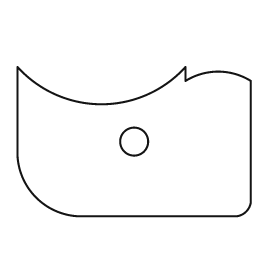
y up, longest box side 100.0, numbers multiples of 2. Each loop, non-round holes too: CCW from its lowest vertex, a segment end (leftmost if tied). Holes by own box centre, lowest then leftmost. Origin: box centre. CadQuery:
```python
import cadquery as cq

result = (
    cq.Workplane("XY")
    .moveTo(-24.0, -32.0)
    .lineTo(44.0, -32.0)
    .threePointArc((48.0, -30.0), (50.0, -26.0))
    .lineTo(50.0, 26.0)
    .threePointArc((36.0, 30.0), (22.0, 26.0))
    .lineTo(22.0, 32.0)
    .threePointArc((-14.0, 16.0), (-50.0, 32.0))
    .lineTo(-50.0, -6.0)
    .threePointArc((-42.0, -24.0), (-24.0, -32.0))
    .close()
    .moveTo(0.0, 0.0)
    .circle(6.0)
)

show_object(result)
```